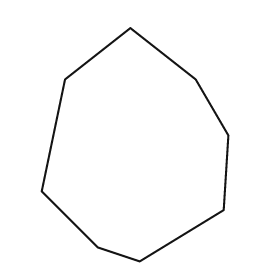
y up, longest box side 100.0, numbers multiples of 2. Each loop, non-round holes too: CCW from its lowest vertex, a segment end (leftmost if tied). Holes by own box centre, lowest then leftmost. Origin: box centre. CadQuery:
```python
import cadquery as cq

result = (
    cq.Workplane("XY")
    .moveTo(2.0, -50.0)
    .lineTo(38.0, -28.0)
    .lineTo(40.0, 4.0)
    .lineTo(26.0, 28.0)
    .lineTo(-2.0, 50.0)
    .lineTo(-30.0, 28.0)
    .lineTo(-40.0, -20.0)
    .lineTo(-16.0, -44.0)
    .close()
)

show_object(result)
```